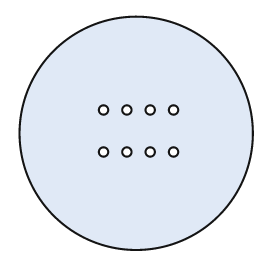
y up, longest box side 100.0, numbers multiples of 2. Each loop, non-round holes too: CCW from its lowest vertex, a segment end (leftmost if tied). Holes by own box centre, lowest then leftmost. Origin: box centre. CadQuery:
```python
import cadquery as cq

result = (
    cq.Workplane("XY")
    .moveTo(0.0, 0.0)
    .circle(50.0)
    .moveTo(-14.0, -8.0)
    .circle(2.0)
    .moveTo(-4.0, -8.0)
    .circle(2.0)
    .moveTo(6.0, -8.0)
    .circle(2.0)
    .moveTo(16.0, -8.0)
    .circle(2.0)
    .moveTo(-14.0, 10.0)
    .circle(2.0)
    .moveTo(-4.0, 10.0)
    .circle(2.0)
    .moveTo(6.0, 10.0)
    .circle(2.0)
    .moveTo(16.0, 10.0)
    .circle(2.0)
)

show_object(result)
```